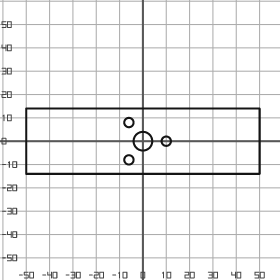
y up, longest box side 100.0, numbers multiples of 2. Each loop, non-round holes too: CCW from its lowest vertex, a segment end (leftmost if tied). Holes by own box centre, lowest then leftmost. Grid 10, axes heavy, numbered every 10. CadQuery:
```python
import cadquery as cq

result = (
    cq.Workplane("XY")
    .moveTo(-50.0, -14.0)
    .lineTo(50.0, -14.0)
    .lineTo(50.0, 14.0)
    .lineTo(-50.0, 14.0)
    .close()
    .moveTo(-6.0, -8.0)
    .circle(2.0)
    .moveTo(0.0, 0.0)
    .circle(4.0)
    .moveTo(10.0, 0.0)
    .circle(2.0)
    .moveTo(-6.0, 8.0)
    .circle(2.0)
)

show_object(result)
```